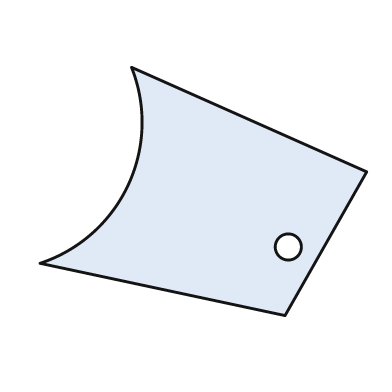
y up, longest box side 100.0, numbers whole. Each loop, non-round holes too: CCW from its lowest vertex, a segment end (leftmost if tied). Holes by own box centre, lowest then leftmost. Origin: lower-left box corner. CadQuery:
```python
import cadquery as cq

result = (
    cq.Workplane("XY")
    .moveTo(75.0, 0.0)
    .lineTo(100.0, 44.0)
    .lineTo(28.0, 76.0)
    .threePointArc((27.0, 40.0), (0.0, 16.0))
    .close()
    .moveTo(76.0, 21.0)
    .circle(4.0)
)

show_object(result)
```